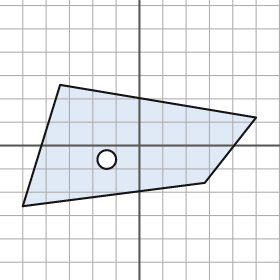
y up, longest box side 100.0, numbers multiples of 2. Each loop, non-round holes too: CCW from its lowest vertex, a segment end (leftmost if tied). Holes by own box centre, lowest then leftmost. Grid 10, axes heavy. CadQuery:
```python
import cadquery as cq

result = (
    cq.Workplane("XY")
    .moveTo(-50.0, -26.0)
    .lineTo(28.0, -16.0)
    .lineTo(50.0, 12.0)
    .lineTo(-34.0, 26.0)
    .close()
    .moveTo(-14.0, -6.0)
    .circle(4.0)
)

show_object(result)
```